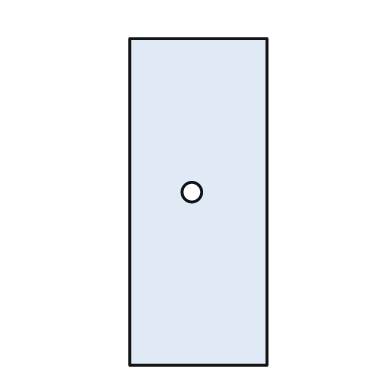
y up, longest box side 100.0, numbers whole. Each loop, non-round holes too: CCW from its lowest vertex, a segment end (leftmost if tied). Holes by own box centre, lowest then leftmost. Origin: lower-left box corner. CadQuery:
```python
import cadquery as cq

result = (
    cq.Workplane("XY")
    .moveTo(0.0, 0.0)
    .lineTo(42.0, 0.0)
    .lineTo(42.0, 100.0)
    .lineTo(0.0, 100.0)
    .close()
    .moveTo(19.0, 53.0)
    .circle(3.0)
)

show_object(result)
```